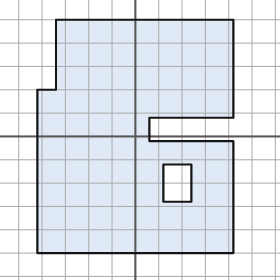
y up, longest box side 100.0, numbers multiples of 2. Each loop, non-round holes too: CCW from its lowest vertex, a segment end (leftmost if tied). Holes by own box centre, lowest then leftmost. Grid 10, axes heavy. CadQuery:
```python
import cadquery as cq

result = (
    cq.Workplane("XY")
    .moveTo(-42.0, -50.0)
    .lineTo(42.0, -50.0)
    .lineTo(42.0, -2.0)
    .lineTo(6.0, -2.0)
    .lineTo(6.0, 8.0)
    .lineTo(42.0, 8.0)
    .lineTo(42.0, 50.0)
    .lineTo(-34.0, 50.0)
    .lineTo(-34.0, 20.0)
    .lineTo(-42.0, 20.0)
    .close()
    .moveTo(12.0, -28.0)
    .lineTo(24.0, -28.0)
    .lineTo(24.0, -12.0)
    .lineTo(12.0, -12.0)
    .close()
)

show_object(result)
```